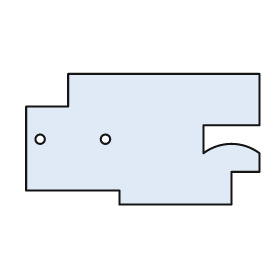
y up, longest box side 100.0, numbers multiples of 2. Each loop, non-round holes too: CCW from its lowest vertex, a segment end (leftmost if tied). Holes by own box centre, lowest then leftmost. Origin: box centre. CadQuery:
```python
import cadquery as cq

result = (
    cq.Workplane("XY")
    .moveTo(-10.0, -28.0)
    .lineTo(38.0, -28.0)
    .lineTo(38.0, -14.0)
    .lineTo(50.0, -14.0)
    .lineTo(50.0, -6.0)
    .threePointArc((38.0, -2.0), (26.0, -6.0))
    .lineTo(26.0, 6.0)
    .lineTo(50.0, 6.0)
    .lineTo(50.0, 28.0)
    .lineTo(-32.0, 28.0)
    .lineTo(-32.0, 14.0)
    .lineTo(-50.0, 14.0)
    .lineTo(-50.0, -22.0)
    .lineTo(-10.0, -22.0)
    .close()
    .moveTo(-44.0, 0.0)
    .circle(2.0)
    .moveTo(-16.0, 0.0)
    .circle(2.0)
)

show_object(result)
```